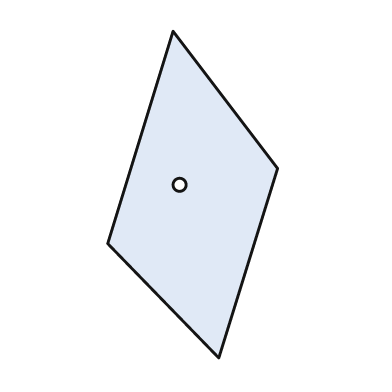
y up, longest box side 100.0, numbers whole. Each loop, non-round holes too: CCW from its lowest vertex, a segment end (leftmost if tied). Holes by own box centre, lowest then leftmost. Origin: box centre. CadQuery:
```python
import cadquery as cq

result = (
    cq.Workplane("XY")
    .moveTo(8.0, -50.0)
    .lineTo(26.0, 8.0)
    .lineTo(-6.0, 50.0)
    .lineTo(-26.0, -15.0)
    .close()
    .moveTo(-4.0, 3.0)
    .circle(2.0)
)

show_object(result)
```